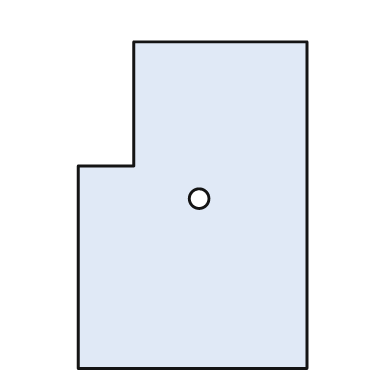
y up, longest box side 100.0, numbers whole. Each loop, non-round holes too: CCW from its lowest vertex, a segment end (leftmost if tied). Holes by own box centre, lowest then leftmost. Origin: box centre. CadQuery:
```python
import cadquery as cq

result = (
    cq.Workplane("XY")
    .moveTo(-35.0, -50.0)
    .lineTo(35.0, -50.0)
    .lineTo(35.0, 50.0)
    .lineTo(-18.0, 50.0)
    .lineTo(-18.0, 12.0)
    .lineTo(-35.0, 12.0)
    .close()
    .moveTo(2.0, 2.0)
    .circle(3.0)
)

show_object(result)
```